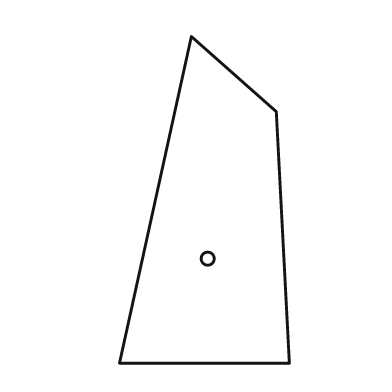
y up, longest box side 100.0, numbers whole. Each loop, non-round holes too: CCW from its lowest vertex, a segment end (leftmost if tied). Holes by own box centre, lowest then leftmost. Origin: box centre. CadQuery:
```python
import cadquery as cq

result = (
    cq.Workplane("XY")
    .moveTo(-26.0, -50.0)
    .lineTo(26.0, -50.0)
    .lineTo(22.0, 27.0)
    .lineTo(-4.0, 50.0)
    .close()
    .moveTo(1.0, -18.0)
    .circle(2.0)
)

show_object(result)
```